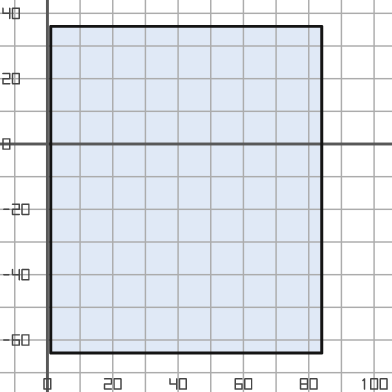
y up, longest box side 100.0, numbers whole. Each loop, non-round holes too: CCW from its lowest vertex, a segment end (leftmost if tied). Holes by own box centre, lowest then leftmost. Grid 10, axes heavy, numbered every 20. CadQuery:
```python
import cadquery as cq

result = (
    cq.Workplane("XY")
    .moveTo(1.0, -64.0)
    .lineTo(84.0, -64.0)
    .lineTo(84.0, 36.0)
    .lineTo(1.0, 36.0)
    .close()
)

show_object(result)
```